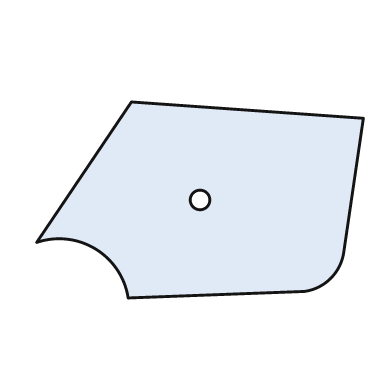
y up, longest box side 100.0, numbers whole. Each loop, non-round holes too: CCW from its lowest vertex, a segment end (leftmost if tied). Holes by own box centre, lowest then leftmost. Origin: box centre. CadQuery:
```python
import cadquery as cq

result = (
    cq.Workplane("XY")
    .moveTo(-22.0, -30.0)
    .lineTo(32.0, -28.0)
    .threePointArc((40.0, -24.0), (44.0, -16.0))
    .lineTo(50.0, 25.0)
    .lineTo(-21.0, 30.0)
    .lineTo(-50.0, -13.0)
    .threePointArc((-32.0, -15.0), (-22.0, -30.0))
    .close()
    .moveTo(0.0, 0.0)
    .circle(3.0)
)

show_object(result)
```